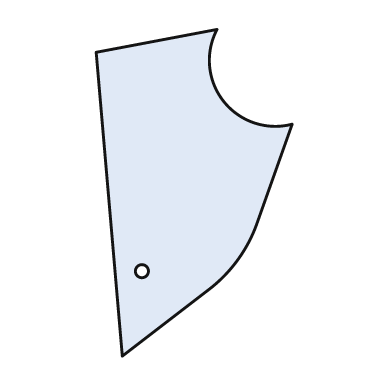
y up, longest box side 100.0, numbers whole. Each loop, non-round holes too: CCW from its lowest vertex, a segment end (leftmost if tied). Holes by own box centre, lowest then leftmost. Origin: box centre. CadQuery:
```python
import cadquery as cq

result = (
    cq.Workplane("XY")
    .moveTo(-22.0, -50.0)
    .lineTo(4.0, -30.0)
    .threePointArc((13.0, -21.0), (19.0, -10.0))
    .lineTo(30.0, 21.0)
    .threePointArc((9.0, 28.0), (7.0, 50.0))
    .lineTo(-30.0, 43.0)
    .close()
    .moveTo(-16.0, -24.0)
    .circle(2.0)
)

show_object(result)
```